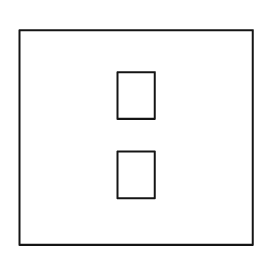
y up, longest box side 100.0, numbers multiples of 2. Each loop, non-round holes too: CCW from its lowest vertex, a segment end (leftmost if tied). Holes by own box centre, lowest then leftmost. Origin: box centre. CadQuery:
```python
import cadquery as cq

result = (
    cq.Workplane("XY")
    .moveTo(-50.0, -46.0)
    .lineTo(50.0, -46.0)
    .lineTo(50.0, 46.0)
    .lineTo(-50.0, 46.0)
    .close()
    .moveTo(-8.0, -26.0)
    .lineTo(8.0, -26.0)
    .lineTo(8.0, -6.0)
    .lineTo(-8.0, -6.0)
    .close()
    .moveTo(-8.0, 8.0)
    .lineTo(8.0, 8.0)
    .lineTo(8.0, 28.0)
    .lineTo(-8.0, 28.0)
    .close()
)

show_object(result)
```